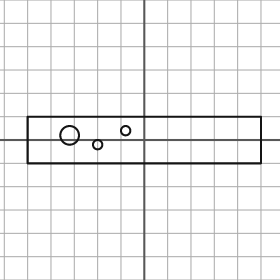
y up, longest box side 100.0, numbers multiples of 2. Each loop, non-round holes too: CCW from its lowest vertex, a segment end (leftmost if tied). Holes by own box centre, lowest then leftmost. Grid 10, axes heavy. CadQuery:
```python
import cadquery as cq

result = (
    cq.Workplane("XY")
    .moveTo(-50.0, -10.0)
    .lineTo(50.0, -10.0)
    .lineTo(50.0, 10.0)
    .lineTo(-50.0, 10.0)
    .close()
    .moveTo(-20.0, -2.0)
    .circle(2.0)
    .moveTo(-32.0, 2.0)
    .circle(4.0)
    .moveTo(-8.0, 4.0)
    .circle(2.0)
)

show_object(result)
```